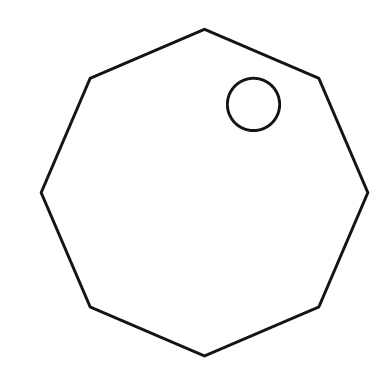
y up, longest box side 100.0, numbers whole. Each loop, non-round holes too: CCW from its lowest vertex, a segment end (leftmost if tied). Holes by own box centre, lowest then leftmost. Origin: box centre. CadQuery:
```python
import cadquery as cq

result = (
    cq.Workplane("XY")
    .moveTo(0.0, -50.0)
    .lineTo(35.0, -35.0)
    .lineTo(50.0, 0.0)
    .lineTo(35.0, 35.0)
    .lineTo(0.0, 50.0)
    .lineTo(-35.0, 35.0)
    .lineTo(-50.0, 0.0)
    .lineTo(-35.0, -35.0)
    .close()
    .moveTo(15.0, 27.0)
    .circle(8.0)
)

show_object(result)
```